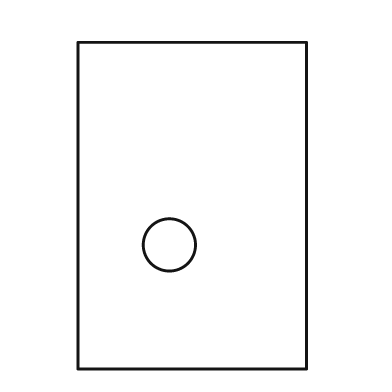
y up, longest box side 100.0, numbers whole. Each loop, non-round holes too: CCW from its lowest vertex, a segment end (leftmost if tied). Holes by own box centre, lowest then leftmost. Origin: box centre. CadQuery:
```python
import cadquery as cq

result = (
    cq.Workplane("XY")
    .moveTo(-35.0, -50.0)
    .lineTo(35.0, -50.0)
    .lineTo(35.0, 50.0)
    .lineTo(-35.0, 50.0)
    .close()
    .moveTo(-7.0, -12.0)
    .circle(8.0)
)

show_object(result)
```